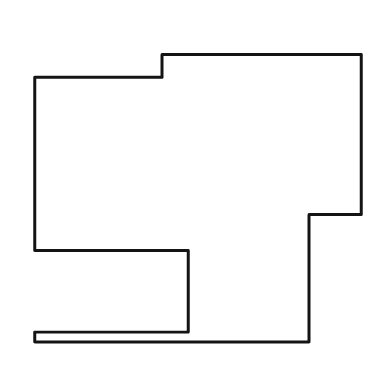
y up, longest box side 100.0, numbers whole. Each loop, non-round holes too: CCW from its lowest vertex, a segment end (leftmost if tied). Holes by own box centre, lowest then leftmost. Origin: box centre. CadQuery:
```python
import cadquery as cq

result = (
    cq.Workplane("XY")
    .moveTo(-50.0, -44.0)
    .lineTo(34.0, -44.0)
    .lineTo(34.0, -5.0)
    .lineTo(50.0, -5.0)
    .lineTo(50.0, 44.0)
    .lineTo(-11.0, 44.0)
    .lineTo(-11.0, 37.0)
    .lineTo(-50.0, 37.0)
    .lineTo(-50.0, -16.0)
    .lineTo(-3.0, -16.0)
    .lineTo(-3.0, -41.0)
    .lineTo(-50.0, -41.0)
    .close()
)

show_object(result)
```